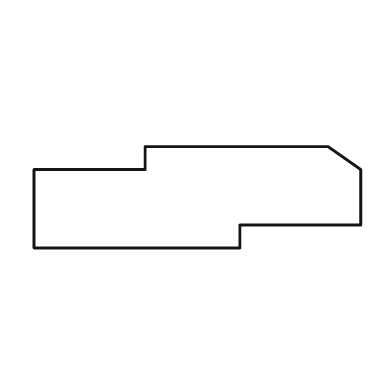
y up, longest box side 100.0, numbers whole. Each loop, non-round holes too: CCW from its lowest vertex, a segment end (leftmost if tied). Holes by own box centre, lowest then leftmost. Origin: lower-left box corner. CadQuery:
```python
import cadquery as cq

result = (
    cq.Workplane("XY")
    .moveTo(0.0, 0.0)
    .lineTo(63.0, 0.0)
    .lineTo(63.0, 7.0)
    .lineTo(100.0, 7.0)
    .lineTo(100.0, 24.0)
    .lineTo(90.0, 31.0)
    .lineTo(34.0, 31.0)
    .lineTo(34.0, 24.0)
    .lineTo(0.0, 24.0)
    .close()
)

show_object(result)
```